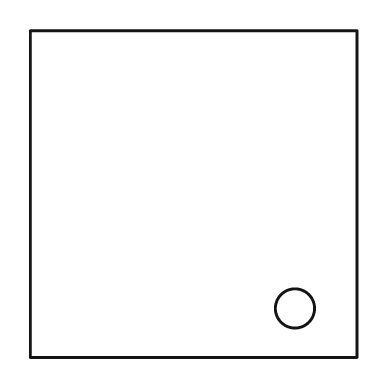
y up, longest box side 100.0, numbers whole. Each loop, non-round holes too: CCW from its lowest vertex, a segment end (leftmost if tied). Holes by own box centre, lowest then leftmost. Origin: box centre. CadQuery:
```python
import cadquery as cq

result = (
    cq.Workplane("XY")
    .moveTo(-50.0, -50.0)
    .lineTo(50.0, -50.0)
    .lineTo(50.0, 50.0)
    .lineTo(-50.0, 50.0)
    .close()
    .moveTo(31.0, -35.0)
    .circle(6.0)
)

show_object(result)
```